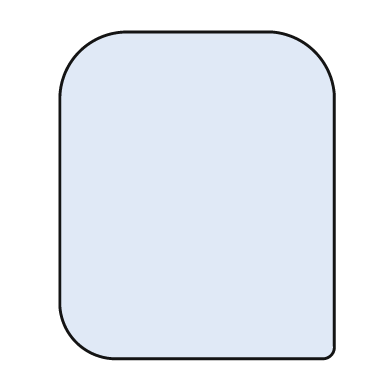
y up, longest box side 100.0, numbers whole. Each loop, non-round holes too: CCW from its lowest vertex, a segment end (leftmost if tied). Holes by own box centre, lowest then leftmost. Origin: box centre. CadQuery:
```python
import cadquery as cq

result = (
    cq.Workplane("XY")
    .moveTo(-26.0, -50.0)
    .lineTo(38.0, -50.0)
    .threePointArc((41.0, -49.0), (42.0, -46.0))
    .lineTo(42.0, 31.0)
    .threePointArc((36.0, 44.0), (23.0, 50.0))
    .lineTo(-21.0, 50.0)
    .threePointArc((-36.0, 44.0), (-42.0, 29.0))
    .lineTo(-42.0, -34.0)
    .threePointArc((-37.0, -45.0), (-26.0, -50.0))
    .close()
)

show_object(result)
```